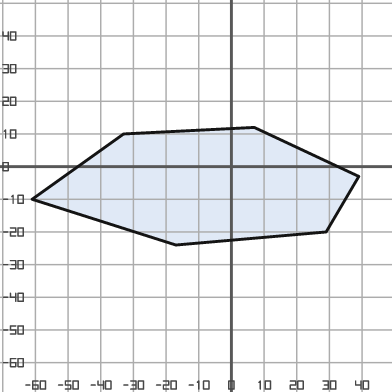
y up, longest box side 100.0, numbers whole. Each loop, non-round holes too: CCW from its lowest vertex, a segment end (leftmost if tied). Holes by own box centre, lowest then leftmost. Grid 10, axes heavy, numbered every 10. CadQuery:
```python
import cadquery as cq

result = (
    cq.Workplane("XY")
    .moveTo(-17.0, -24.0)
    .lineTo(29.0, -20.0)
    .lineTo(39.0, -3.0)
    .lineTo(7.0, 12.0)
    .lineTo(-33.0, 10.0)
    .lineTo(-61.0, -10.0)
    .close()
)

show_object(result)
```